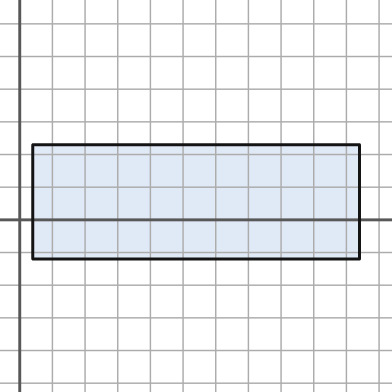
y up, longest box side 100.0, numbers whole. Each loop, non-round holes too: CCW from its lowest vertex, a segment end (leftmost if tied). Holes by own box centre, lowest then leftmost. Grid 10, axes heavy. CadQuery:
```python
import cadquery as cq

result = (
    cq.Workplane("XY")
    .moveTo(4.0, -12.0)
    .lineTo(104.0, -12.0)
    .lineTo(104.0, 23.0)
    .lineTo(4.0, 23.0)
    .close()
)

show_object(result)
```